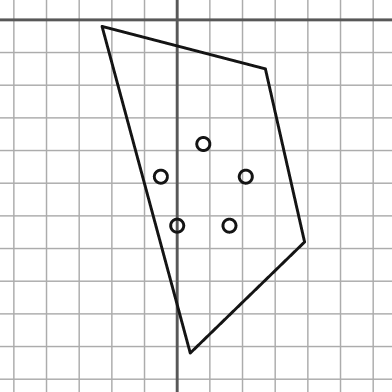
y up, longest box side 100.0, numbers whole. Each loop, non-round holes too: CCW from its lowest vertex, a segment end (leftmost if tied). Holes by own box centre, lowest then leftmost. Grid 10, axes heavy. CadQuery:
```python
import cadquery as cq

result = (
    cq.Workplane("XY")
    .moveTo(4.0, -102.0)
    .lineTo(39.0, -68.0)
    .lineTo(27.0, -15.0)
    .lineTo(-23.0, -2.0)
    .close()
    .moveTo(0.0, -63.0)
    .circle(2.0)
    .moveTo(16.0, -63.0)
    .circle(2.0)
    .moveTo(-5.0, -48.0)
    .circle(2.0)
    .moveTo(21.0, -48.0)
    .circle(2.0)
    .moveTo(8.0, -38.0)
    .circle(2.0)
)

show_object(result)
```